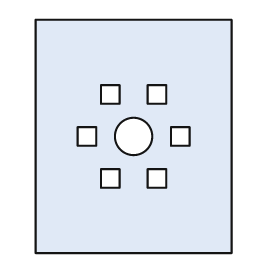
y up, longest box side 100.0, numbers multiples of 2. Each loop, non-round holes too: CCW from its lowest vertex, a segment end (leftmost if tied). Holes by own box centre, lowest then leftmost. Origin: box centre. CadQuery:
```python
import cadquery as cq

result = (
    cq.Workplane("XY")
    .moveTo(-42.0, -50.0)
    .lineTo(42.0, -50.0)
    .lineTo(42.0, 50.0)
    .lineTo(-42.0, 50.0)
    .close()
    .moveTo(-14.0, -22.0)
    .lineTo(-6.0, -22.0)
    .lineTo(-6.0, -14.0)
    .lineTo(-14.0, -14.0)
    .close()
    .moveTo(6.0, -22.0)
    .lineTo(14.0, -22.0)
    .lineTo(14.0, -14.0)
    .lineTo(6.0, -14.0)
    .close()
    .moveTo(-24.0, -4.0)
    .lineTo(-16.0, -4.0)
    .lineTo(-16.0, 4.0)
    .lineTo(-24.0, 4.0)
    .close()
    .moveTo(0.0, 0.0)
    .circle(8.0)
    .moveTo(16.0, -4.0)
    .lineTo(24.0, -4.0)
    .lineTo(24.0, 4.0)
    .lineTo(16.0, 4.0)
    .close()
    .moveTo(-14.0, 14.0)
    .lineTo(-6.0, 14.0)
    .lineTo(-6.0, 22.0)
    .lineTo(-14.0, 22.0)
    .close()
    .moveTo(6.0, 14.0)
    .lineTo(14.0, 14.0)
    .lineTo(14.0, 22.0)
    .lineTo(6.0, 22.0)
    .close()
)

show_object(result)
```